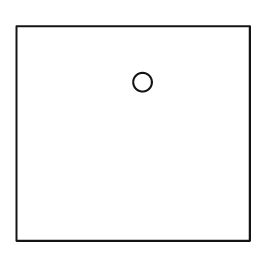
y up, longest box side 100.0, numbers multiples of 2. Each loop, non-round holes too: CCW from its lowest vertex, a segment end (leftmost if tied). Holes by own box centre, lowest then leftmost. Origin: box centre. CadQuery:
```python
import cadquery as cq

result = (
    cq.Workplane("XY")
    .moveTo(-50.0, -46.0)
    .lineTo(50.0, -46.0)
    .lineTo(50.0, 46.0)
    .lineTo(-50.0, 46.0)
    .close()
    .moveTo(4.0, 22.0)
    .circle(4.0)
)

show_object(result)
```